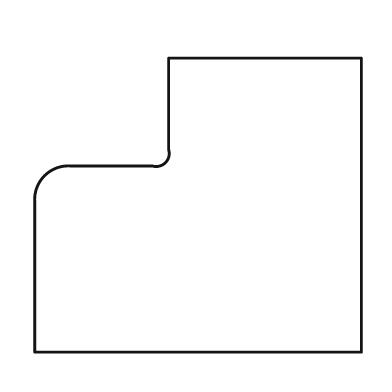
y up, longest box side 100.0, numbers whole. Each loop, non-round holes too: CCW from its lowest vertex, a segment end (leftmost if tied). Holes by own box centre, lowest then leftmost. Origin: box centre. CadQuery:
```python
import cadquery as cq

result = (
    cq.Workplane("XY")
    .moveTo(-50.0, -45.0)
    .lineTo(50.0, -45.0)
    .lineTo(50.0, 45.0)
    .lineTo(-9.0, 45.0)
    .lineTo(-9.0, 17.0)
    .threePointArc((-10.0, 13.0), (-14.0, 12.0))
    .lineTo(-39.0, 12.0)
    .threePointArc((-47.0, 9.0), (-50.0, 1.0))
    .close()
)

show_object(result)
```